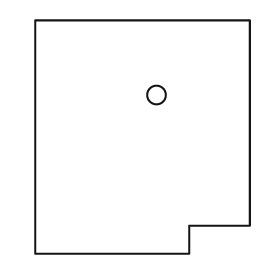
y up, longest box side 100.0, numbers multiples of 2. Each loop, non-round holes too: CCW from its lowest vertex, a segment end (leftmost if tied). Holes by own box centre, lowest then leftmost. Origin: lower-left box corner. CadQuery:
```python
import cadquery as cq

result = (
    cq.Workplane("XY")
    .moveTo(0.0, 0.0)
    .lineTo(66.0, 0.0)
    .lineTo(66.0, 12.0)
    .lineTo(92.0, 12.0)
    .lineTo(92.0, 100.0)
    .lineTo(0.0, 100.0)
    .close()
    .moveTo(52.0, 68.0)
    .circle(4.0)
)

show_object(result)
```